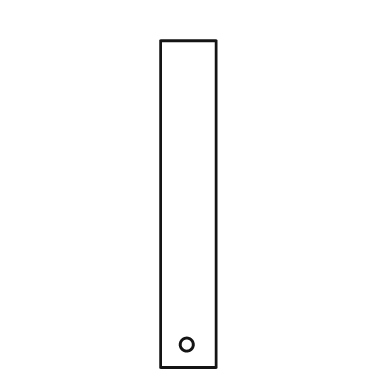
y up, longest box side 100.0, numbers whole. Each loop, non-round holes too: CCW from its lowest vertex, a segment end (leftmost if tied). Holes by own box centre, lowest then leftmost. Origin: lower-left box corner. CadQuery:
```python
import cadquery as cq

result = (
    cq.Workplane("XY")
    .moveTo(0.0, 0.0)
    .lineTo(17.0, 0.0)
    .lineTo(17.0, 100.0)
    .lineTo(0.0, 100.0)
    .close()
    .moveTo(8.0, 7.0)
    .circle(2.0)
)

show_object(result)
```